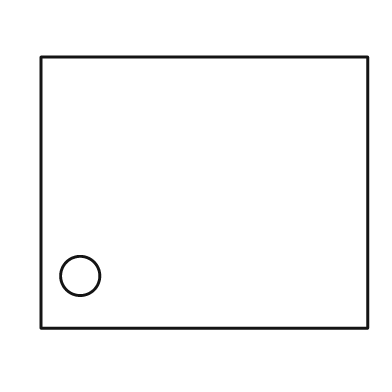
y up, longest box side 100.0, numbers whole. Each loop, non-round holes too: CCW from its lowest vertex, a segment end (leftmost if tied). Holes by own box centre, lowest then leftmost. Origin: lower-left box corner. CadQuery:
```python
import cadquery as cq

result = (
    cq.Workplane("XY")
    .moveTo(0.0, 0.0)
    .lineTo(100.0, 0.0)
    .lineTo(100.0, 83.0)
    .lineTo(0.0, 83.0)
    .close()
    .moveTo(12.0, 16.0)
    .circle(6.0)
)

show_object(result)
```